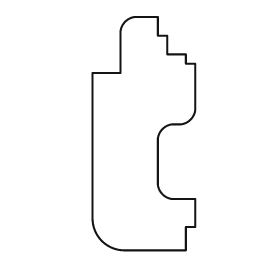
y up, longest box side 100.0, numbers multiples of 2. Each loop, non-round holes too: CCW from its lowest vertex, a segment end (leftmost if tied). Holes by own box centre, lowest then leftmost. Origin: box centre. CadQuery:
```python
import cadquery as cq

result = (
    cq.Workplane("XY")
    .moveTo(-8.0, -50.0)
    .lineTo(18.0, -50.0)
    .lineTo(18.0, -40.0)
    .lineTo(22.0, -40.0)
    .lineTo(22.0, -28.0)
    .lineTo(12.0, -28.0)
    .threePointArc((8.0, -26.0), (6.0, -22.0))
    .lineTo(6.0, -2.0)
    .threePointArc((8.0, 2.0), (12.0, 4.0))
    .lineTo(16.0, 4.0)
    .threePointArc((20.0, 6.0), (22.0, 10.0))
    .lineTo(22.0, 30.0)
    .lineTo(18.0, 30.0)
    .lineTo(18.0, 34.0)
    .lineTo(10.0, 34.0)
    .lineTo(10.0, 42.0)
    .lineTo(6.0, 42.0)
    .lineTo(6.0, 50.0)
    .lineTo(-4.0, 50.0)
    .threePointArc((-8.0, 48.0), (-10.0, 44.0))
    .lineTo(-10.0, 26.0)
    .lineTo(-22.0, 26.0)
    .lineTo(-22.0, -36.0)
    .threePointArc((-18.0, -46.0), (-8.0, -50.0))
    .close()
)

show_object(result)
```